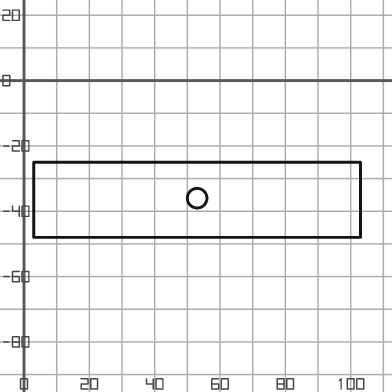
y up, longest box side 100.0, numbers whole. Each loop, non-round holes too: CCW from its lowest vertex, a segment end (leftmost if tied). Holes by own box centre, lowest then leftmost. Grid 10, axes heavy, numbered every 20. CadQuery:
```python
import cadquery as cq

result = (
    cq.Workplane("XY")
    .moveTo(3.0, -48.0)
    .lineTo(103.0, -48.0)
    .lineTo(103.0, -25.0)
    .lineTo(3.0, -25.0)
    .close()
    .moveTo(53.0, -36.0)
    .circle(3.0)
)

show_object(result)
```